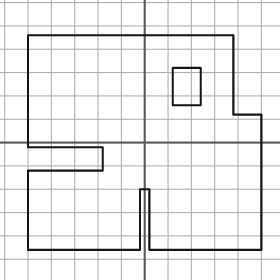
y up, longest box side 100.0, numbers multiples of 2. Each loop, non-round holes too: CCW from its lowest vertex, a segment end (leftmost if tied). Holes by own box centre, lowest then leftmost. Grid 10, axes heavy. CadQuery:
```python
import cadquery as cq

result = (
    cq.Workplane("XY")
    .moveTo(-50.0, -46.0)
    .lineTo(-2.0, -46.0)
    .lineTo(-2.0, -20.0)
    .lineTo(2.0, -20.0)
    .lineTo(2.0, -46.0)
    .lineTo(50.0, -46.0)
    .lineTo(50.0, 12.0)
    .lineTo(38.0, 12.0)
    .lineTo(38.0, 46.0)
    .lineTo(-50.0, 46.0)
    .lineTo(-50.0, -2.0)
    .lineTo(-18.0, -2.0)
    .lineTo(-18.0, -12.0)
    .lineTo(-50.0, -12.0)
    .close()
    .moveTo(12.0, 16.0)
    .lineTo(24.0, 16.0)
    .lineTo(24.0, 32.0)
    .lineTo(12.0, 32.0)
    .close()
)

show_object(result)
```